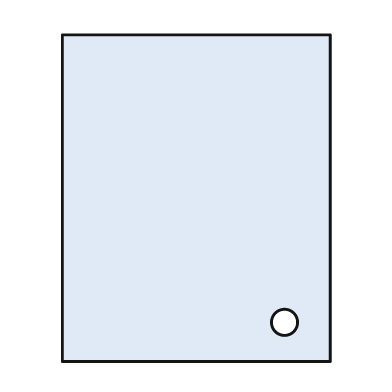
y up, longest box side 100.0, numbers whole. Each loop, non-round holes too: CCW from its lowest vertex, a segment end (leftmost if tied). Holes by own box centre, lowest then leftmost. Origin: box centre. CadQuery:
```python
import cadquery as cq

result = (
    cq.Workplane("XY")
    .moveTo(-41.0, -50.0)
    .lineTo(41.0, -50.0)
    .lineTo(41.0, 50.0)
    .lineTo(-41.0, 50.0)
    .close()
    .moveTo(27.0, -38.0)
    .circle(4.0)
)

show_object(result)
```